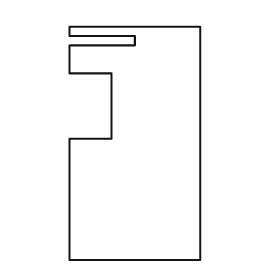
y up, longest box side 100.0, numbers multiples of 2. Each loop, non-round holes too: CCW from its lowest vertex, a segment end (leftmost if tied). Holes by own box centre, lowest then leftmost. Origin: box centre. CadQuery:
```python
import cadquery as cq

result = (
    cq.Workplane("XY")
    .moveTo(-28.0, -50.0)
    .lineTo(28.0, -50.0)
    .lineTo(28.0, 50.0)
    .lineTo(-28.0, 50.0)
    .lineTo(-28.0, 46.0)
    .lineTo(0.0, 46.0)
    .lineTo(0.0, 42.0)
    .lineTo(-28.0, 42.0)
    .lineTo(-28.0, 30.0)
    .lineTo(-10.0, 30.0)
    .lineTo(-10.0, 2.0)
    .lineTo(-28.0, 2.0)
    .close()
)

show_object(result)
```